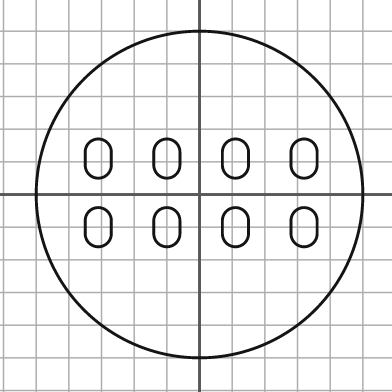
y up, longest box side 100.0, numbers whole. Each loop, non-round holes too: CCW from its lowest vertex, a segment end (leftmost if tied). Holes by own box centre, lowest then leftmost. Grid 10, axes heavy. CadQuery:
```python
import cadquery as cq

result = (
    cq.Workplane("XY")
    .moveTo(0.0, 0.0)
    .circle(50.0)
    .moveTo(-35.0, -12.0)
    .threePointArc((-31.0, -16.0), (-27.0, -12.0))
    .lineTo(-27.0, -8.0)
    .threePointArc((-31.0, -4.0), (-35.0, -8.0))
    .close()
    .moveTo(-14.0, -12.0)
    .threePointArc((-10.0, -16.0), (-6.0, -12.0))
    .lineTo(-6.0, -8.0)
    .threePointArc((-10.0, -4.0), (-14.0, -8.0))
    .close()
    .moveTo(7.0, -12.0)
    .threePointArc((11.0, -16.0), (15.0, -12.0))
    .lineTo(15.0, -8.0)
    .threePointArc((11.0, -4.0), (7.0, -8.0))
    .close()
    .moveTo(28.0, -12.0)
    .threePointArc((32.0, -16.0), (36.0, -12.0))
    .lineTo(36.0, -8.0)
    .threePointArc((32.0, -4.0), (28.0, -8.0))
    .close()
    .moveTo(-35.0, 9.0)
    .threePointArc((-31.0, 5.0), (-27.0, 9.0))
    .lineTo(-27.0, 13.0)
    .threePointArc((-31.0, 17.0), (-35.0, 13.0))
    .close()
    .moveTo(-14.0, 9.0)
    .threePointArc((-10.0, 5.0), (-6.0, 9.0))
    .lineTo(-6.0, 13.0)
    .threePointArc((-10.0, 17.0), (-14.0, 13.0))
    .close()
    .moveTo(7.0, 9.0)
    .threePointArc((11.0, 5.0), (15.0, 9.0))
    .lineTo(15.0, 13.0)
    .threePointArc((11.0, 17.0), (7.0, 13.0))
    .close()
    .moveTo(28.0, 9.0)
    .threePointArc((32.0, 5.0), (36.0, 9.0))
    .lineTo(36.0, 13.0)
    .threePointArc((32.0, 17.0), (28.0, 13.0))
    .close()
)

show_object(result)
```